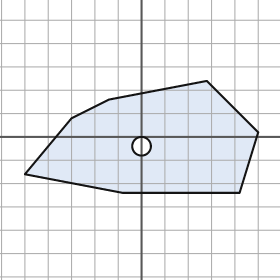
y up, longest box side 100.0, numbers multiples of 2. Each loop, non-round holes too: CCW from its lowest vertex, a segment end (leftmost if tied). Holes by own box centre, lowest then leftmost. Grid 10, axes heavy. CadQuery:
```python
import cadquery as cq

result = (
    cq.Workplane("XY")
    .moveTo(-8.0, -24.0)
    .lineTo(42.0, -24.0)
    .lineTo(50.0, 2.0)
    .lineTo(28.0, 24.0)
    .lineTo(-14.0, 16.0)
    .lineTo(-30.0, 8.0)
    .lineTo(-50.0, -16.0)
    .close()
    .moveTo(0.0, -4.0)
    .circle(4.0)
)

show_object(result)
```